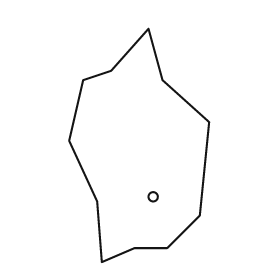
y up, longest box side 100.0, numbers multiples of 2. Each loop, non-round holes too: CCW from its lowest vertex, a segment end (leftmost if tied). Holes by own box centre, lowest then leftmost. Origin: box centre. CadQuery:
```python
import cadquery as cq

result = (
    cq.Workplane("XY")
    .moveTo(-16.0, -50.0)
    .lineTo(-2.0, -44.0)
    .lineTo(12.0, -44.0)
    .lineTo(26.0, -30.0)
    .lineTo(30.0, 10.0)
    .lineTo(10.0, 28.0)
    .lineTo(4.0, 50.0)
    .lineTo(-12.0, 32.0)
    .lineTo(-24.0, 28.0)
    .lineTo(-30.0, 2.0)
    .lineTo(-18.0, -24.0)
    .close()
    .moveTo(6.0, -22.0)
    .circle(2.0)
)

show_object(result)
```